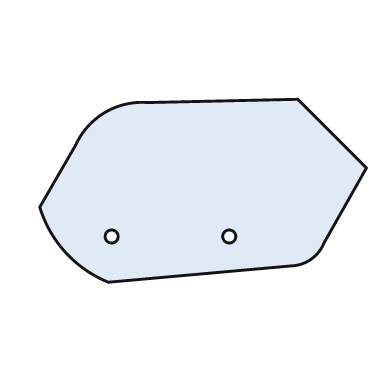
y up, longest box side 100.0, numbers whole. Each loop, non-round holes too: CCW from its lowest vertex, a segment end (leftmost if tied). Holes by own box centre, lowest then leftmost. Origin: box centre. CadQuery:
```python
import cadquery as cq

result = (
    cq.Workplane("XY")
    .moveTo(-29.0, -28.0)
    .lineTo(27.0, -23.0)
    .threePointArc((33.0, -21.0), (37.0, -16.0))
    .lineTo(50.0, 7.0)
    .lineTo(29.0, 28.0)
    .lineTo(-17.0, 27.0)
    .threePointArc((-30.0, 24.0), (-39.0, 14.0))
    .lineTo(-50.0, -5.0)
    .threePointArc((-42.0, -19.0), (-29.0, -28.0))
    .close()
    .moveTo(-28.0, -14.0)
    .circle(2.0)
    .moveTo(8.0, -14.0)
    .circle(2.0)
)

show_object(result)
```